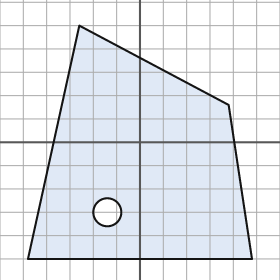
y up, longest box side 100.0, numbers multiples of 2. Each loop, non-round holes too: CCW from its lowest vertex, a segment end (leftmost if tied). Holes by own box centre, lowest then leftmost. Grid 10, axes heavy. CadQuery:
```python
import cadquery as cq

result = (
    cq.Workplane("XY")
    .moveTo(-48.0, -50.0)
    .lineTo(48.0, -50.0)
    .lineTo(38.0, 16.0)
    .lineTo(-26.0, 50.0)
    .close()
    .moveTo(-14.0, -30.0)
    .circle(6.0)
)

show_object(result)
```